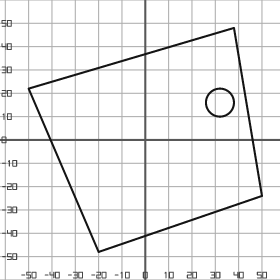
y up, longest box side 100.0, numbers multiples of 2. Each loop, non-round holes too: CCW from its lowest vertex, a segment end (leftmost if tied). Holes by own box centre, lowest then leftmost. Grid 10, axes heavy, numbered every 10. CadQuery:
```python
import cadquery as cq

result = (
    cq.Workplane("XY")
    .moveTo(-20.0, -48.0)
    .lineTo(50.0, -24.0)
    .lineTo(38.0, 48.0)
    .lineTo(-50.0, 22.0)
    .close()
    .moveTo(32.0, 16.0)
    .circle(6.0)
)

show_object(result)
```